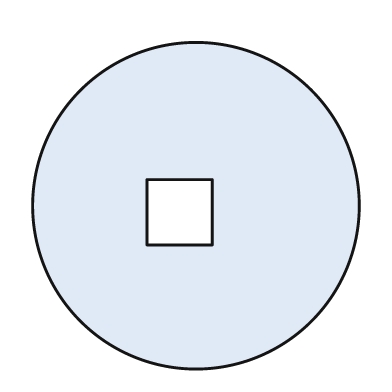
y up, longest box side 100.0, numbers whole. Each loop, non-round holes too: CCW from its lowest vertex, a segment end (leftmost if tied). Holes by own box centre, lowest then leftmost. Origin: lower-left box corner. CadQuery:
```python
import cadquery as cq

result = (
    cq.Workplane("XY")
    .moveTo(50.0, 50.0)
    .circle(50.0)
    .moveTo(35.0, 38.0)
    .lineTo(55.0, 38.0)
    .lineTo(55.0, 58.0)
    .lineTo(35.0, 58.0)
    .close()
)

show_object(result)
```